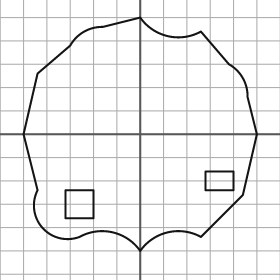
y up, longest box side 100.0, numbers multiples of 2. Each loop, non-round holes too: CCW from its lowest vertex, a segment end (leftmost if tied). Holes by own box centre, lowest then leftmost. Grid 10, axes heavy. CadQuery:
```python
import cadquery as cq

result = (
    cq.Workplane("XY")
    .moveTo(0.0, -50.0)
    .threePointArc((12.0, -42.0), (26.0, -44.0))
    .lineTo(44.0, -26.0)
    .lineTo(50.0, 0.0)
    .lineTo(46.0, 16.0)
    .threePointArc((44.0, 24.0), (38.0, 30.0))
    .lineTo(26.0, 44.0)
    .threePointArc((12.0, 42.0), (0.0, 50.0))
    .lineTo(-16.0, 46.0)
    .threePointArc((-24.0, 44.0), (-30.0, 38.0))
    .lineTo(-44.0, 26.0)
    .lineTo(-50.0, 0.0)
    .lineTo(-44.0, -24.0)
    .threePointArc((-42.0, -40.0), (-26.0, -44.0))
    .threePointArc((-12.0, -42.0), (0.0, -50.0))
    .close()
    .moveTo(-32.0, -36.0)
    .lineTo(-20.0, -36.0)
    .lineTo(-20.0, -24.0)
    .lineTo(-32.0, -24.0)
    .close()
    .moveTo(28.0, -24.0)
    .lineTo(40.0, -24.0)
    .lineTo(40.0, -16.0)
    .lineTo(28.0, -16.0)
    .close()
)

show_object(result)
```